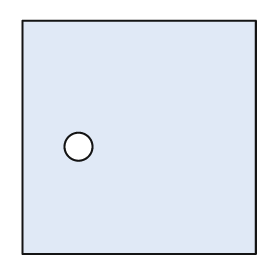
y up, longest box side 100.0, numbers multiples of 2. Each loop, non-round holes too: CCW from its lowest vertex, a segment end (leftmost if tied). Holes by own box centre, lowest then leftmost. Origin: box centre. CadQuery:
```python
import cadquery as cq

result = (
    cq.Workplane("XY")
    .moveTo(-50.0, -50.0)
    .lineTo(50.0, -50.0)
    .lineTo(50.0, 50.0)
    .lineTo(-50.0, 50.0)
    .close()
    .moveTo(-26.0, -4.0)
    .circle(6.0)
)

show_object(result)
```